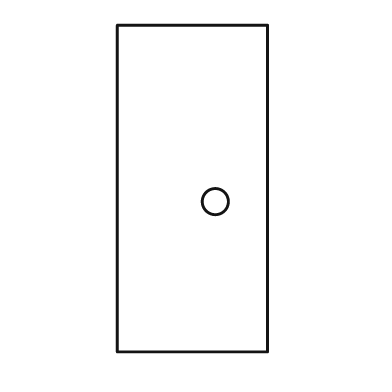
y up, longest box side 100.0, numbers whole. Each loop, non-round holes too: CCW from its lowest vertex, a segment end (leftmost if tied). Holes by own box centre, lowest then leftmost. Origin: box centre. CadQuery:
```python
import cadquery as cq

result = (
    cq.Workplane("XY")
    .moveTo(-23.0, -50.0)
    .lineTo(23.0, -50.0)
    .lineTo(23.0, 50.0)
    .lineTo(-23.0, 50.0)
    .close()
    .moveTo(7.0, -4.0)
    .circle(4.0)
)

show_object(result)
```